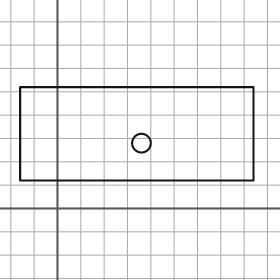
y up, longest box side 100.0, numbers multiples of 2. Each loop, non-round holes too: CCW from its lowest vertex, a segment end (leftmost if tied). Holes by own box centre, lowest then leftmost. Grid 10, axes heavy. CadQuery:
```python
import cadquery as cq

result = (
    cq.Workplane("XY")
    .moveTo(-16.0, 12.0)
    .lineTo(84.0, 12.0)
    .lineTo(84.0, 52.0)
    .lineTo(-16.0, 52.0)
    .close()
    .moveTo(36.0, 28.0)
    .circle(4.0)
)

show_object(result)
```